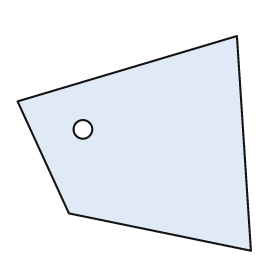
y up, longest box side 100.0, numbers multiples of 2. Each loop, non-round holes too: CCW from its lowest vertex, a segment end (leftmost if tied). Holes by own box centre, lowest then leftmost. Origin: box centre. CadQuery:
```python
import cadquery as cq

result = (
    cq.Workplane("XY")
    .moveTo(50.0, -46.0)
    .lineTo(44.0, 46.0)
    .lineTo(-50.0, 18.0)
    .lineTo(-28.0, -30.0)
    .close()
    .moveTo(-22.0, 6.0)
    .circle(4.0)
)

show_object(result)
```